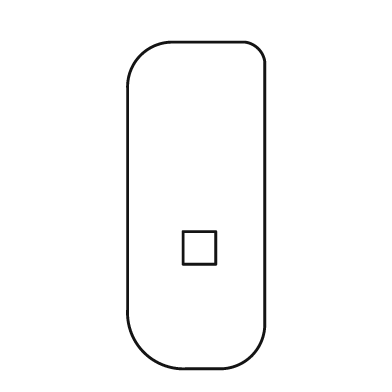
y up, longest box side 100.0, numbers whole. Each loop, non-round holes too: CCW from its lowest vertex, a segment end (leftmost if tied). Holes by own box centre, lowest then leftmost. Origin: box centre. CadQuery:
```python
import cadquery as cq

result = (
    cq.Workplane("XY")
    .moveTo(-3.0, -50.0)
    .lineTo(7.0, -50.0)
    .threePointArc((17.0, -46.0), (21.0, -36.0))
    .lineTo(21.0, 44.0)
    .threePointArc((19.0, 48.0), (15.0, 50.0))
    .lineTo(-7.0, 50.0)
    .threePointArc((-17.0, 46.0), (-21.0, 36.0))
    .lineTo(-21.0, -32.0)
    .threePointArc((-16.0, -45.0), (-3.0, -50.0))
    .close()
    .moveTo(-4.0, -18.0)
    .lineTo(6.0, -18.0)
    .lineTo(6.0, -8.0)
    .lineTo(-4.0, -8.0)
    .close()
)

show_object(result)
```